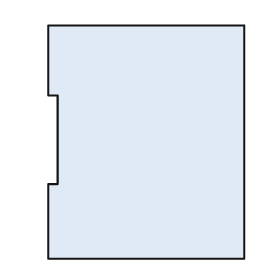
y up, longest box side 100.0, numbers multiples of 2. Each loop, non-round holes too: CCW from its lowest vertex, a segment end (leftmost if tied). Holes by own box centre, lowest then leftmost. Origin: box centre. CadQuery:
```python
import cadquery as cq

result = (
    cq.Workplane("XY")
    .moveTo(-42.0, -50.0)
    .lineTo(42.0, -50.0)
    .lineTo(42.0, 50.0)
    .lineTo(-42.0, 50.0)
    .lineTo(-42.0, 20.0)
    .lineTo(-38.0, 20.0)
    .lineTo(-38.0, -18.0)
    .lineTo(-42.0, -18.0)
    .close()
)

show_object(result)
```